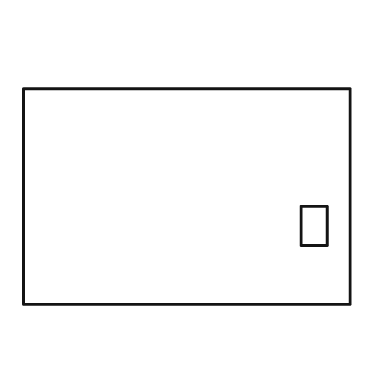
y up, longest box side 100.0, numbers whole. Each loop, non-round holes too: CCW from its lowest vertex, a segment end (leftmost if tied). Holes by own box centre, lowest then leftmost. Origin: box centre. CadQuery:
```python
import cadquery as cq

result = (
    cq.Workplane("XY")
    .moveTo(-50.0, -33.0)
    .lineTo(50.0, -33.0)
    .lineTo(50.0, 33.0)
    .lineTo(-50.0, 33.0)
    .close()
    .moveTo(35.0, -15.0)
    .lineTo(43.0, -15.0)
    .lineTo(43.0, -3.0)
    .lineTo(35.0, -3.0)
    .close()
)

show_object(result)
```